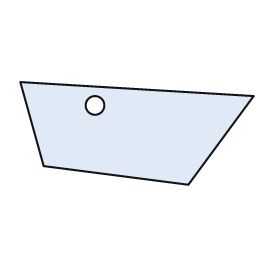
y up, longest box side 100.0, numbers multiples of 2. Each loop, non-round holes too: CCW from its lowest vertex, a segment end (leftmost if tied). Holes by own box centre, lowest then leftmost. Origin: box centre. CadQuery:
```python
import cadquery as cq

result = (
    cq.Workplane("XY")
    .moveTo(22.0, -22.0)
    .lineTo(50.0, 16.0)
    .lineTo(-50.0, 22.0)
    .lineTo(-40.0, -14.0)
    .close()
    .moveTo(-18.0, 12.0)
    .circle(4.0)
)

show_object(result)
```